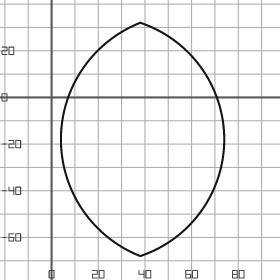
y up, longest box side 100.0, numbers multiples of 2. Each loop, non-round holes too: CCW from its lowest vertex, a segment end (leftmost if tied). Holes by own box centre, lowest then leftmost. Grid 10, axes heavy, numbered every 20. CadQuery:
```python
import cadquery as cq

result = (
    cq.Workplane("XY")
    .moveTo(38.0, -68.0)
    .threePointArc((74.0, -18.0), (38.0, 32.0))
    .threePointArc((4.0, -18.0), (38.0, -68.0))
    .close()
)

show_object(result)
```